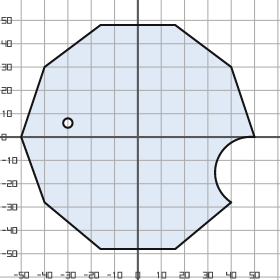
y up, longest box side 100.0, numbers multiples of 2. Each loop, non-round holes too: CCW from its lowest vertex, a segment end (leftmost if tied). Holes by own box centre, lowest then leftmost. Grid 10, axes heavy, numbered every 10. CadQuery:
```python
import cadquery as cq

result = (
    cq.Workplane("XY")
    .moveTo(-16.0, -48.0)
    .lineTo(16.0, -48.0)
    .lineTo(40.0, -28.0)
    .threePointArc((34.0, -10.0), (50.0, 0.0))
    .lineTo(40.0, 30.0)
    .lineTo(16.0, 48.0)
    .lineTo(-16.0, 48.0)
    .lineTo(-40.0, 30.0)
    .lineTo(-50.0, 0.0)
    .lineTo(-40.0, -28.0)
    .close()
    .moveTo(-30.0, 6.0)
    .circle(2.0)
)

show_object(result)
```